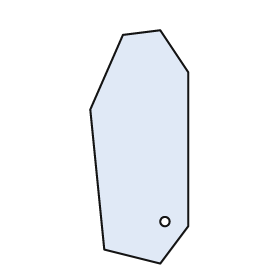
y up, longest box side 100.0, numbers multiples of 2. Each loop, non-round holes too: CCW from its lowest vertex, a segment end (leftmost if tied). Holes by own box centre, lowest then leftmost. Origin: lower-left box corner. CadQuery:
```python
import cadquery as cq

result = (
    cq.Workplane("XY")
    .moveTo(30.0, 0.0)
    .lineTo(42.0, 16.0)
    .lineTo(42.0, 82.0)
    .lineTo(30.0, 100.0)
    .lineTo(14.0, 98.0)
    .lineTo(0.0, 66.0)
    .lineTo(6.0, 6.0)
    .close()
    .moveTo(32.0, 18.0)
    .circle(2.0)
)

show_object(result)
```